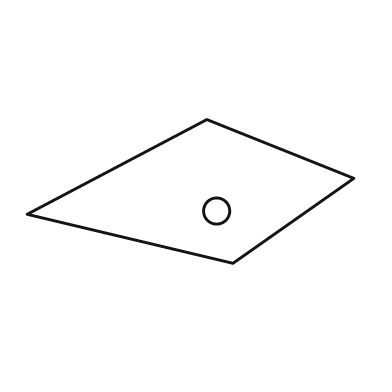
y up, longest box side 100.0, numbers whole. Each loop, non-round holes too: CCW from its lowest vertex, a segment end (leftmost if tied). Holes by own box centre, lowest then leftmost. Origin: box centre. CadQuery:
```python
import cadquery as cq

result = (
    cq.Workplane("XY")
    .moveTo(13.0, -22.0)
    .lineTo(50.0, 4.0)
    .lineTo(5.0, 22.0)
    .lineTo(-50.0, -7.0)
    .close()
    .moveTo(8.0, -6.0)
    .circle(4.0)
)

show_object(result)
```